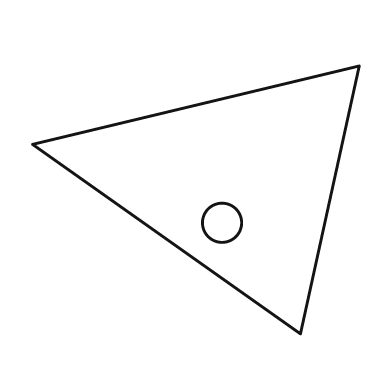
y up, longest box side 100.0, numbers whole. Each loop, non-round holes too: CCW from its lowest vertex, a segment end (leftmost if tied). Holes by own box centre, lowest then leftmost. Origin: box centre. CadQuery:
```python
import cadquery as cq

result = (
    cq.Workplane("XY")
    .moveTo(32.0, -41.0)
    .lineTo(50.0, 41.0)
    .lineTo(-50.0, 17.0)
    .close()
    .moveTo(8.0, -7.0)
    .circle(6.0)
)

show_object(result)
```